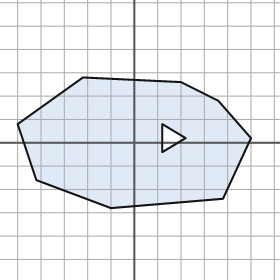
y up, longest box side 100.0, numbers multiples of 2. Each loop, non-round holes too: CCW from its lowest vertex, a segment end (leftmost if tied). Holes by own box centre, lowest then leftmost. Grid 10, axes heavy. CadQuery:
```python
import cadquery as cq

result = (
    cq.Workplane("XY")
    .moveTo(-10.0, -28.0)
    .lineTo(38.0, -24.0)
    .lineTo(50.0, 2.0)
    .lineTo(36.0, 18.0)
    .lineTo(20.0, 26.0)
    .lineTo(-22.0, 28.0)
    .lineTo(-50.0, 8.0)
    .lineTo(-42.0, -16.0)
    .close()
    .moveTo(12.0, -4.0)
    .lineTo(22.0, 2.0)
    .lineTo(12.0, 8.0)
    .close()
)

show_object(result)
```